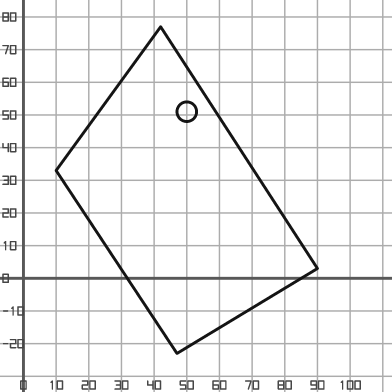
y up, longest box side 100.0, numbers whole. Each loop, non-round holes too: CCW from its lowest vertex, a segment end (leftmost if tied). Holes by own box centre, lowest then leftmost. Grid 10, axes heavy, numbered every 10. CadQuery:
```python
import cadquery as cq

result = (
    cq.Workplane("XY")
    .moveTo(47.0, -23.0)
    .lineTo(90.0, 3.0)
    .lineTo(42.0, 77.0)
    .lineTo(10.0, 33.0)
    .close()
    .moveTo(50.0, 51.0)
    .circle(3.0)
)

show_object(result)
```